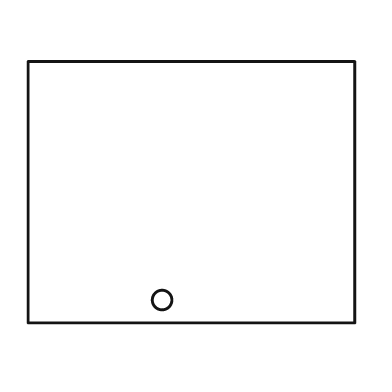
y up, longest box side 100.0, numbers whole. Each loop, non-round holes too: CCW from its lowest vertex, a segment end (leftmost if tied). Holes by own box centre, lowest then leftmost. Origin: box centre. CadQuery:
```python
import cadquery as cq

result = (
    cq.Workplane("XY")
    .moveTo(-50.0, -40.0)
    .lineTo(50.0, -40.0)
    .lineTo(50.0, 40.0)
    .lineTo(-50.0, 40.0)
    .close()
    .moveTo(-9.0, -33.0)
    .circle(3.0)
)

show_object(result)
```